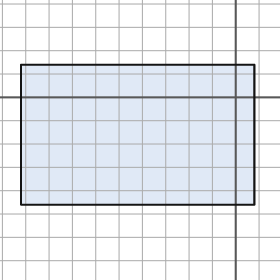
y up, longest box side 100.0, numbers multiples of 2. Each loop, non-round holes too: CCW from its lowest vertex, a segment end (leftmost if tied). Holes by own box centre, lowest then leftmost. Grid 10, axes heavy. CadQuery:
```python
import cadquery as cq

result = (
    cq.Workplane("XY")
    .moveTo(-92.0, -46.0)
    .lineTo(8.0, -46.0)
    .lineTo(8.0, 14.0)
    .lineTo(-92.0, 14.0)
    .close()
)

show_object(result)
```